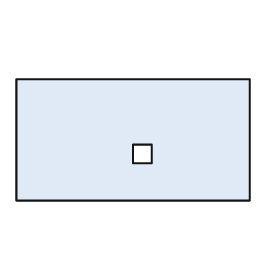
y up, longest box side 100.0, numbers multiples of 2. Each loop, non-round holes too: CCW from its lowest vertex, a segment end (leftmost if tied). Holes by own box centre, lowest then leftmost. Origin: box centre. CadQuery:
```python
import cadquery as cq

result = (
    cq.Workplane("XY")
    .moveTo(-50.0, -26.0)
    .lineTo(50.0, -26.0)
    .lineTo(50.0, 26.0)
    .lineTo(-50.0, 26.0)
    .close()
    .moveTo(0.0, -10.0)
    .lineTo(8.0, -10.0)
    .lineTo(8.0, -2.0)
    .lineTo(0.0, -2.0)
    .close()
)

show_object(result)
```